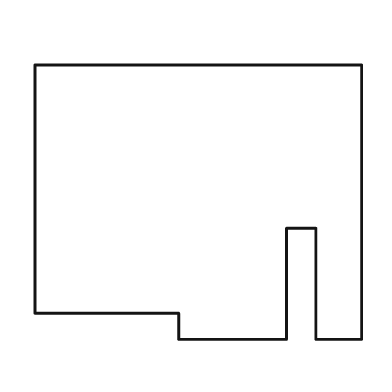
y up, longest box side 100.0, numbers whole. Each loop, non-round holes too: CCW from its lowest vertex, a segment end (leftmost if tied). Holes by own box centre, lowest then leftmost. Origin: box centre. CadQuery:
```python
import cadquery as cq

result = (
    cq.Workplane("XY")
    .moveTo(-6.0, -42.0)
    .lineTo(27.0, -42.0)
    .lineTo(27.0, -8.0)
    .lineTo(36.0, -8.0)
    .lineTo(36.0, -42.0)
    .lineTo(50.0, -42.0)
    .lineTo(50.0, 42.0)
    .lineTo(-50.0, 42.0)
    .lineTo(-50.0, -34.0)
    .lineTo(-6.0, -34.0)
    .close()
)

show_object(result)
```